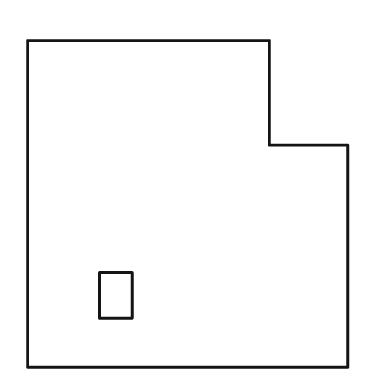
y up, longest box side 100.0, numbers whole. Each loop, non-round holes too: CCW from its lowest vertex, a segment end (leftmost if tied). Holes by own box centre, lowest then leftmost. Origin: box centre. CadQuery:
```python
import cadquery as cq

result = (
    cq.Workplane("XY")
    .moveTo(-49.0, -50.0)
    .lineTo(49.0, -50.0)
    .lineTo(49.0, 18.0)
    .lineTo(25.0, 18.0)
    .lineTo(25.0, 50.0)
    .lineTo(-49.0, 50.0)
    .close()
    .moveTo(-27.0, -35.0)
    .lineTo(-17.0, -35.0)
    .lineTo(-17.0, -21.0)
    .lineTo(-27.0, -21.0)
    .close()
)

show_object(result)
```